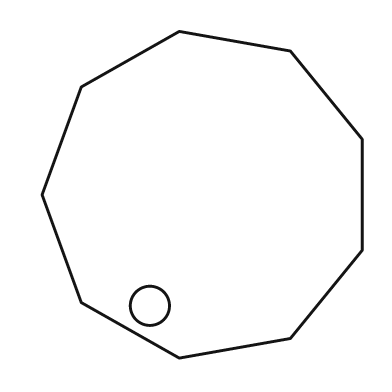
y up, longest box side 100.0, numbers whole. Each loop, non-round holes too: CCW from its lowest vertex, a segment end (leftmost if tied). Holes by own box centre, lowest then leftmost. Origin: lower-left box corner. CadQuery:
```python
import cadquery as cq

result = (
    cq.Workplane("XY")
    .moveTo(42.0, 0.0)
    .lineTo(76.0, 6.0)
    .lineTo(98.0, 33.0)
    .lineTo(98.0, 67.0)
    .lineTo(76.0, 94.0)
    .lineTo(42.0, 100.0)
    .lineTo(12.0, 83.0)
    .lineTo(0.0, 50.0)
    .lineTo(12.0, 17.0)
    .close()
    .moveTo(33.0, 16.0)
    .circle(6.0)
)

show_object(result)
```